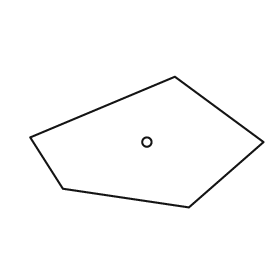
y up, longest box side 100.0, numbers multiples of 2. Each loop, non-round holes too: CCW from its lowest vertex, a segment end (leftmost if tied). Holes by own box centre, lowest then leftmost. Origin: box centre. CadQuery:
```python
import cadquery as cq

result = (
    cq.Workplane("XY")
    .moveTo(18.0, -28.0)
    .lineTo(50.0, 0.0)
    .lineTo(12.0, 28.0)
    .lineTo(-50.0, 2.0)
    .lineTo(-36.0, -20.0)
    .close()
    .moveTo(0.0, 0.0)
    .circle(2.0)
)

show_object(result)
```